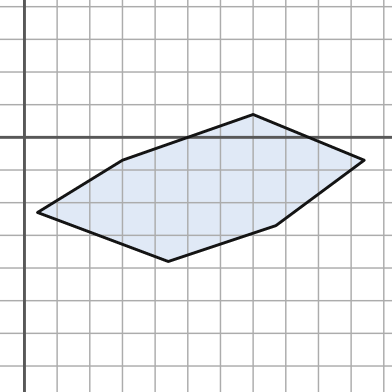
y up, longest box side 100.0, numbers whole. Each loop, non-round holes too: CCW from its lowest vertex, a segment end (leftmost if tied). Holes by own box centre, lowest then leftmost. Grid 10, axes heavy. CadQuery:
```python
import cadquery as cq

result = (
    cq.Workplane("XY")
    .moveTo(44.0, -38.0)
    .lineTo(77.0, -27.0)
    .lineTo(104.0, -7.0)
    .lineTo(70.0, 7.0)
    .lineTo(30.0, -7.0)
    .lineTo(4.0, -23.0)
    .close()
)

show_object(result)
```